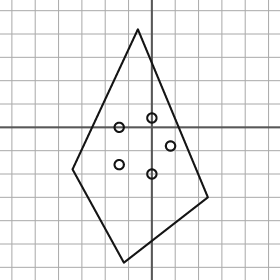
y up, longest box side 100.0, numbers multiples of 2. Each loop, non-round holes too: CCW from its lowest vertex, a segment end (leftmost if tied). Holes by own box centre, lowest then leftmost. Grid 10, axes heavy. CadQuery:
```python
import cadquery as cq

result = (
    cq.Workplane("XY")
    .moveTo(-12.0, -58.0)
    .lineTo(24.0, -30.0)
    .lineTo(-6.0, 42.0)
    .lineTo(-34.0, -18.0)
    .close()
    .moveTo(0.0, -20.0)
    .circle(2.0)
    .moveTo(-14.0, -16.0)
    .circle(2.0)
    .moveTo(8.0, -8.0)
    .circle(2.0)
    .moveTo(-14.0, 0.0)
    .circle(2.0)
    .moveTo(0.0, 4.0)
    .circle(2.0)
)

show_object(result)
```